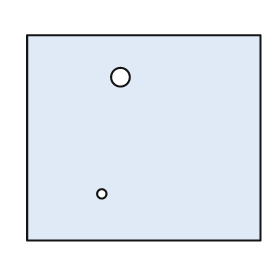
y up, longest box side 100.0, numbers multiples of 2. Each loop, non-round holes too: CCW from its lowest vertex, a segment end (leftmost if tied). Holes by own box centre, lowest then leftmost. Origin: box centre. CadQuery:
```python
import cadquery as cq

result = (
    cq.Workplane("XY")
    .moveTo(-50.0, -44.0)
    .lineTo(50.0, -44.0)
    .lineTo(50.0, 44.0)
    .lineTo(-50.0, 44.0)
    .close()
    .moveTo(-18.0, -24.0)
    .circle(2.0)
    .moveTo(-10.0, 26.0)
    .circle(4.0)
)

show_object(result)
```